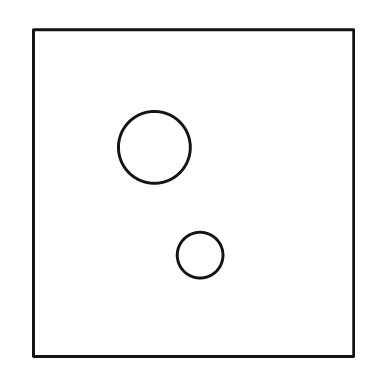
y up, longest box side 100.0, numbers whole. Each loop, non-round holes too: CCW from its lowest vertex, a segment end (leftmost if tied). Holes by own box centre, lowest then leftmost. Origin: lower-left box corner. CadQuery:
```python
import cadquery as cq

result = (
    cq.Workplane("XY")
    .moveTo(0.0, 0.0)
    .lineTo(98.0, 0.0)
    .lineTo(98.0, 100.0)
    .lineTo(0.0, 100.0)
    .close()
    .moveTo(51.0, 31.0)
    .circle(7.0)
    .moveTo(37.0, 64.0)
    .circle(11.0)
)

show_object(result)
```